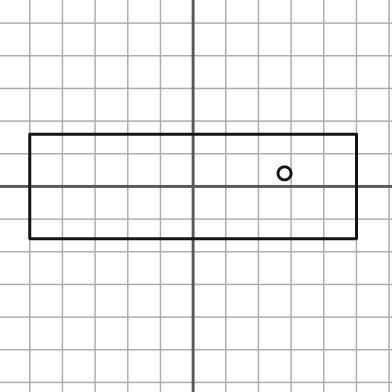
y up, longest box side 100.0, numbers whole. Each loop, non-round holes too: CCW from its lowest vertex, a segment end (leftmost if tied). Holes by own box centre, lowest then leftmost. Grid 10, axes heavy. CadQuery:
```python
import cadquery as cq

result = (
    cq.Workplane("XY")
    .moveTo(-50.0, -16.0)
    .lineTo(50.0, -16.0)
    .lineTo(50.0, 16.0)
    .lineTo(-50.0, 16.0)
    .close()
    .moveTo(28.0, 4.0)
    .circle(2.0)
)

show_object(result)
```